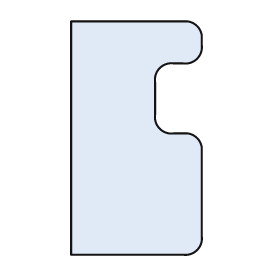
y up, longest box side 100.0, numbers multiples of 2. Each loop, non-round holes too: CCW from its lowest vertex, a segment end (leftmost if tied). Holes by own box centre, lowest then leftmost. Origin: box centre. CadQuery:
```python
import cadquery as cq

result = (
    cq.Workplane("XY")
    .moveTo(-28.0, -50.0)
    .lineTo(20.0, -50.0)
    .threePointArc((26.0, -48.0), (28.0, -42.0))
    .lineTo(28.0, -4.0)
    .threePointArc((26.0, 0.0), (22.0, 2.0))
    .lineTo(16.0, 2.0)
    .threePointArc((10.0, 4.0), (8.0, 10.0))
    .lineTo(8.0, 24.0)
    .threePointArc((10.0, 30.0), (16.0, 32.0))
    .lineTo(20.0, 32.0)
    .threePointArc((26.0, 34.0), (28.0, 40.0))
    .lineTo(28.0, 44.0)
    .threePointArc((26.0, 48.0), (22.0, 50.0))
    .lineTo(-28.0, 50.0)
    .close()
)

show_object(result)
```